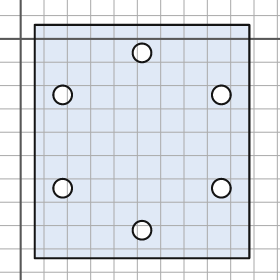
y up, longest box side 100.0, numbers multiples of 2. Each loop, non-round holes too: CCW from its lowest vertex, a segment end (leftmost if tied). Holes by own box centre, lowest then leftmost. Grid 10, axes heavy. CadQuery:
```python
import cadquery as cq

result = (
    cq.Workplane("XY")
    .moveTo(6.0, -94.0)
    .lineTo(98.0, -94.0)
    .lineTo(98.0, 6.0)
    .lineTo(6.0, 6.0)
    .close()
    .moveTo(52.0, -82.0)
    .circle(4.0)
    .moveTo(18.0, -64.0)
    .circle(4.0)
    .moveTo(86.0, -64.0)
    .circle(4.0)
    .moveTo(18.0, -24.0)
    .circle(4.0)
    .moveTo(86.0, -24.0)
    .circle(4.0)
    .moveTo(52.0, -6.0)
    .circle(4.0)
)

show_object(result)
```